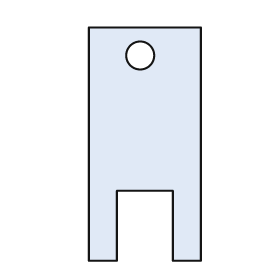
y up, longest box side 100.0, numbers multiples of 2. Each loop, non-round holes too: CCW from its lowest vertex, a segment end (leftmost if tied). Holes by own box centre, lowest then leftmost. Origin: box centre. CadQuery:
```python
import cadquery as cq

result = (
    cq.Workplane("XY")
    .moveTo(-24.0, -50.0)
    .lineTo(-12.0, -50.0)
    .lineTo(-12.0, -20.0)
    .lineTo(12.0, -20.0)
    .lineTo(12.0, -50.0)
    .lineTo(24.0, -50.0)
    .lineTo(24.0, 50.0)
    .lineTo(-24.0, 50.0)
    .close()
    .moveTo(-2.0, 38.0)
    .circle(6.0)
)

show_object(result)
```